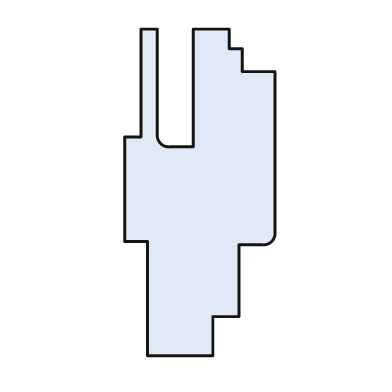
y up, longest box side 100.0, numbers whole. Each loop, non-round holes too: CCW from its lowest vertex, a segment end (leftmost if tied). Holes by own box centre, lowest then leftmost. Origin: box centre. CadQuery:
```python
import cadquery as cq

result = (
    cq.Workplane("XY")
    .moveTo(-16.0, -50.0)
    .lineTo(4.0, -50.0)
    .lineTo(4.0, -38.0)
    .lineTo(12.0, -38.0)
    .lineTo(12.0, -16.0)
    .lineTo(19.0, -16.0)
    .threePointArc((22.0, -15.0), (23.0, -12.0))
    .lineTo(23.0, 37.0)
    .lineTo(13.0, 37.0)
    .lineTo(13.0, 44.0)
    .lineTo(9.0, 44.0)
    .lineTo(9.0, 50.0)
    .lineTo(-2.0, 50.0)
    .lineTo(-2.0, 14.0)
    .lineTo(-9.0, 14.0)
    .threePointArc((-12.0, 15.0), (-13.0, 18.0))
    .lineTo(-13.0, 50.0)
    .lineTo(-18.0, 50.0)
    .lineTo(-18.0, 17.0)
    .lineTo(-23.0, 17.0)
    .lineTo(-23.0, -15.0)
    .lineTo(-16.0, -15.0)
    .close()
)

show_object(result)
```